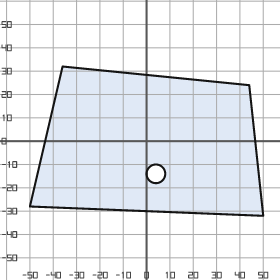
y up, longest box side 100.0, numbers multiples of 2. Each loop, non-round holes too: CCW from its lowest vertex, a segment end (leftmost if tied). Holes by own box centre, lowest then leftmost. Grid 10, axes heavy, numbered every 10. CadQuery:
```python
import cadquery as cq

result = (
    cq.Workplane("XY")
    .moveTo(50.0, -32.0)
    .lineTo(44.0, 24.0)
    .lineTo(-36.0, 32.0)
    .lineTo(-50.0, -28.0)
    .close()
    .moveTo(4.0, -14.0)
    .circle(4.0)
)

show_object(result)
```